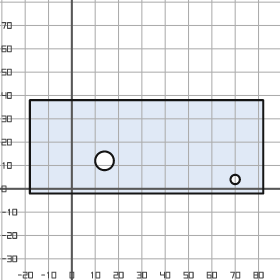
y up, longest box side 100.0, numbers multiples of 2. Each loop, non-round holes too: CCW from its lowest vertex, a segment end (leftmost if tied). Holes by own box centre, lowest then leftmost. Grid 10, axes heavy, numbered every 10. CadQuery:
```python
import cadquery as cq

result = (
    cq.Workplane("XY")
    .moveTo(-18.0, -2.0)
    .lineTo(82.0, -2.0)
    .lineTo(82.0, 38.0)
    .lineTo(-18.0, 38.0)
    .close()
    .moveTo(70.0, 4.0)
    .circle(2.0)
    .moveTo(14.0, 12.0)
    .circle(4.0)
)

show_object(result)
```